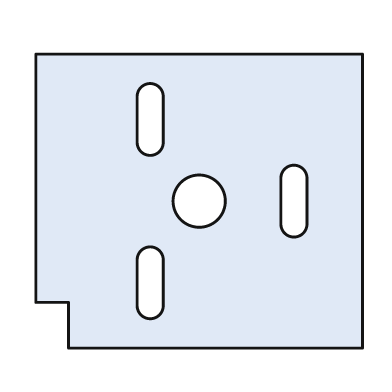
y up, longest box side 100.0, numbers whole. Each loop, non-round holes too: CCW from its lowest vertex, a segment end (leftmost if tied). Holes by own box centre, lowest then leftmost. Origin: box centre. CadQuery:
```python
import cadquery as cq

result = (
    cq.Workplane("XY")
    .moveTo(-40.0, -45.0)
    .lineTo(50.0, -45.0)
    .lineTo(50.0, 45.0)
    .lineTo(-50.0, 45.0)
    .lineTo(-50.0, -31.0)
    .lineTo(-40.0, -31.0)
    .close()
    .moveTo(-19.0, -32.0)
    .threePointArc((-15.0, -36.0), (-11.0, -32.0))
    .lineTo(-11.0, -18.0)
    .threePointArc((-15.0, -14.0), (-19.0, -18.0))
    .close()
    .moveTo(0.0, 0.0)
    .circle(8.0)
    .moveTo(25.0, -7.0)
    .threePointArc((29.0, -11.0), (33.0, -7.0))
    .lineTo(33.0, 7.0)
    .threePointArc((29.0, 11.0), (25.0, 7.0))
    .close()
    .moveTo(-19.0, 18.0)
    .threePointArc((-15.0, 14.0), (-11.0, 18.0))
    .lineTo(-11.0, 32.0)
    .threePointArc((-15.0, 36.0), (-19.0, 32.0))
    .close()
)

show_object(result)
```